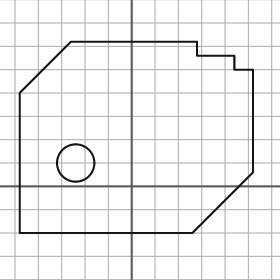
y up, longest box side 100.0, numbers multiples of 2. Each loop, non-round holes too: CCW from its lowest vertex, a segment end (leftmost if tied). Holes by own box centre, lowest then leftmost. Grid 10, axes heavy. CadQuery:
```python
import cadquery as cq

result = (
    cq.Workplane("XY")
    .moveTo(-48.0, -20.0)
    .lineTo(26.0, -20.0)
    .lineTo(52.0, 6.0)
    .lineTo(52.0, 50.0)
    .lineTo(44.0, 50.0)
    .lineTo(44.0, 56.0)
    .lineTo(28.0, 56.0)
    .lineTo(28.0, 62.0)
    .lineTo(-26.0, 62.0)
    .lineTo(-48.0, 40.0)
    .close()
    .moveTo(-24.0, 10.0)
    .circle(8.0)
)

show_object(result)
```